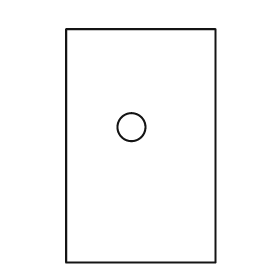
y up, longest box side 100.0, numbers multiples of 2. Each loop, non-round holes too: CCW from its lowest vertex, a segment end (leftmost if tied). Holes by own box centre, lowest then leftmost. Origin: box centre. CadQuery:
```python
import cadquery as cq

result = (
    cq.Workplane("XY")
    .moveTo(-32.0, -50.0)
    .lineTo(32.0, -50.0)
    .lineTo(32.0, 50.0)
    .lineTo(-32.0, 50.0)
    .close()
    .moveTo(-4.0, 8.0)
    .circle(6.0)
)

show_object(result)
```